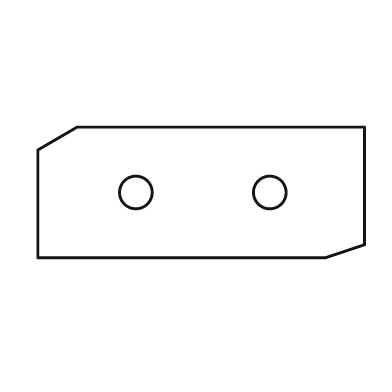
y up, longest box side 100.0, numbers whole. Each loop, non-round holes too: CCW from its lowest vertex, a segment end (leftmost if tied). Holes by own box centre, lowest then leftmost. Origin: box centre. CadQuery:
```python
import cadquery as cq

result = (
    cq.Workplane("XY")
    .moveTo(-50.0, -20.0)
    .lineTo(38.0, -20.0)
    .lineTo(50.0, -16.0)
    .lineTo(50.0, 20.0)
    .lineTo(-38.0, 20.0)
    .lineTo(-50.0, 13.0)
    .close()
    .moveTo(-20.0, 0.0)
    .circle(5.0)
    .moveTo(21.0, 0.0)
    .circle(5.0)
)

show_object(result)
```